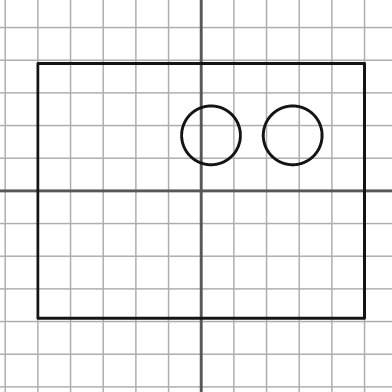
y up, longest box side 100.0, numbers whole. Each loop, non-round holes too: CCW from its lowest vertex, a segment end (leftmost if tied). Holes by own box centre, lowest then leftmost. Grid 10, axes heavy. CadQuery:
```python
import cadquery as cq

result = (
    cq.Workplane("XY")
    .moveTo(-50.0, -39.0)
    .lineTo(50.0, -39.0)
    .lineTo(50.0, 39.0)
    .lineTo(-50.0, 39.0)
    .close()
    .moveTo(3.0, 17.0)
    .circle(9.0)
    .moveTo(28.0, 17.0)
    .circle(9.0)
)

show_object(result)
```